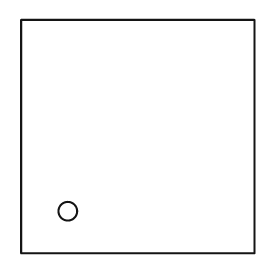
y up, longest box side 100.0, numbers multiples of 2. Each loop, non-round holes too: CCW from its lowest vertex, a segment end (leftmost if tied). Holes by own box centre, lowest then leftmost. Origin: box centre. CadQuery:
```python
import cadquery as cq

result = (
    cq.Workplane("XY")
    .moveTo(-50.0, -50.0)
    .lineTo(50.0, -50.0)
    .lineTo(50.0, 50.0)
    .lineTo(-50.0, 50.0)
    .close()
    .moveTo(-30.0, -32.0)
    .circle(4.0)
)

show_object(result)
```